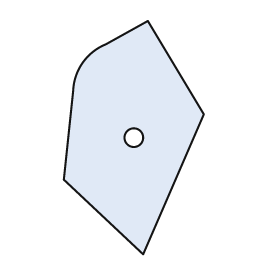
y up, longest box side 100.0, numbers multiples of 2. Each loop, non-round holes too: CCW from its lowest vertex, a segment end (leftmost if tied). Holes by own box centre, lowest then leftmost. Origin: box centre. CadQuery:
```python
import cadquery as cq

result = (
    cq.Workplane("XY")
    .moveTo(4.0, -50.0)
    .lineTo(30.0, 10.0)
    .lineTo(6.0, 50.0)
    .lineTo(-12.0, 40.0)
    .threePointArc((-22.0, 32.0), (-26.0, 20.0))
    .lineTo(-30.0, -18.0)
    .close()
    .moveTo(0.0, 0.0)
    .circle(4.0)
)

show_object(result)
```